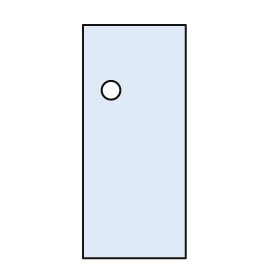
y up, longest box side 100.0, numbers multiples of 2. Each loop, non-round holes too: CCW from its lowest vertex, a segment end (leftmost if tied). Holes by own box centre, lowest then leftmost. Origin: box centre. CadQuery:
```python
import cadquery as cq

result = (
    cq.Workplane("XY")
    .moveTo(-22.0, -50.0)
    .lineTo(22.0, -50.0)
    .lineTo(22.0, 50.0)
    .lineTo(-22.0, 50.0)
    .close()
    .moveTo(-10.0, 22.0)
    .circle(4.0)
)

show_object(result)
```